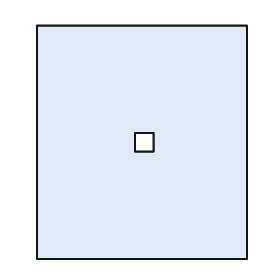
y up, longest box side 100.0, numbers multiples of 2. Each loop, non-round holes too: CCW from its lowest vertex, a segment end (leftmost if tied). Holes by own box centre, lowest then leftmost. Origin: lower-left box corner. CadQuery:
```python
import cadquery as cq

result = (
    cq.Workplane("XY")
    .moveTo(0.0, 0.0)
    .lineTo(90.0, 0.0)
    .lineTo(90.0, 100.0)
    .lineTo(0.0, 100.0)
    .close()
    .moveTo(42.0, 46.0)
    .lineTo(50.0, 46.0)
    .lineTo(50.0, 54.0)
    .lineTo(42.0, 54.0)
    .close()
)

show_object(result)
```